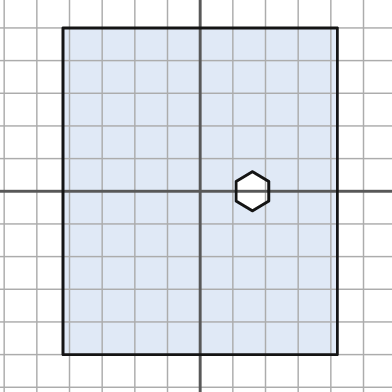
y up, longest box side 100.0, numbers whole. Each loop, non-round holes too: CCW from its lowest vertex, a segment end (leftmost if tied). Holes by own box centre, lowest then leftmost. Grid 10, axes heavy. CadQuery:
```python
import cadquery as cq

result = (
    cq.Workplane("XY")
    .moveTo(-42.0, -50.0)
    .lineTo(42.0, -50.0)
    .lineTo(42.0, 50.0)
    .lineTo(-42.0, 50.0)
    .close()
    .moveTo(16.0, -6.0)
    .lineTo(21.0, -3.0)
    .lineTo(21.0, 3.0)
    .lineTo(16.0, 6.0)
    .lineTo(11.0, 3.0)
    .lineTo(11.0, -3.0)
    .close()
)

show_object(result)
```